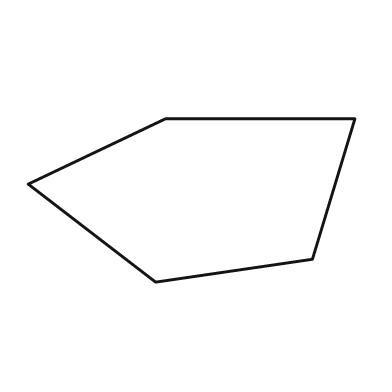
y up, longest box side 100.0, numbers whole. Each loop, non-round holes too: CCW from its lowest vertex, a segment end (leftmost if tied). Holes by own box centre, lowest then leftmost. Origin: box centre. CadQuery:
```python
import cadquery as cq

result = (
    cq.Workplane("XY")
    .moveTo(-11.0, -25.0)
    .lineTo(37.0, -18.0)
    .lineTo(50.0, 25.0)
    .lineTo(-8.0, 25.0)
    .lineTo(-50.0, 5.0)
    .close()
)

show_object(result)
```